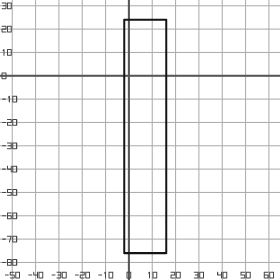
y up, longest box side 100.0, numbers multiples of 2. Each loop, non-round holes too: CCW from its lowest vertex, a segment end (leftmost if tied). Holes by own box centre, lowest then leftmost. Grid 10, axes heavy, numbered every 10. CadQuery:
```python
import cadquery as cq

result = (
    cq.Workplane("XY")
    .moveTo(-2.0, -76.0)
    .lineTo(16.0, -76.0)
    .lineTo(16.0, 24.0)
    .lineTo(-2.0, 24.0)
    .close()
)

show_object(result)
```